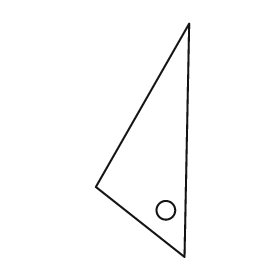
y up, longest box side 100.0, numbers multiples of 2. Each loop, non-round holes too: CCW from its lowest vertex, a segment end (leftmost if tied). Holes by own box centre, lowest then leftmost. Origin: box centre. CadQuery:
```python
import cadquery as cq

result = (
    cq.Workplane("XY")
    .moveTo(18.0, -50.0)
    .lineTo(20.0, 50.0)
    .lineTo(-20.0, -20.0)
    .close()
    .moveTo(10.0, -30.0)
    .circle(4.0)
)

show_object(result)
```